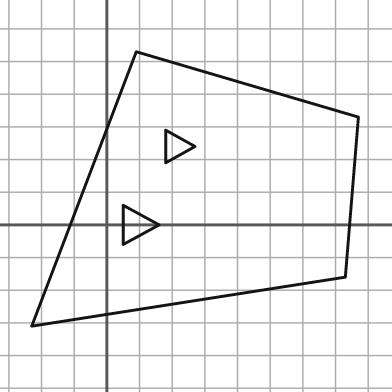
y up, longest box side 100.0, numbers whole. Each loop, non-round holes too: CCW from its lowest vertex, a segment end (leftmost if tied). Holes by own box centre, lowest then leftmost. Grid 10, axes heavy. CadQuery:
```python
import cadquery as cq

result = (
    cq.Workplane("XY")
    .moveTo(-23.0, -31.0)
    .lineTo(73.0, -16.0)
    .lineTo(77.0, 33.0)
    .lineTo(9.0, 53.0)
    .close()
    .moveTo(5.0, -6.0)
    .lineTo(16.0, 0.0)
    .lineTo(5.0, 6.0)
    .close()
    .moveTo(18.0, 19.0)
    .lineTo(27.0, 24.0)
    .lineTo(18.0, 29.0)
    .close()
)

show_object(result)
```